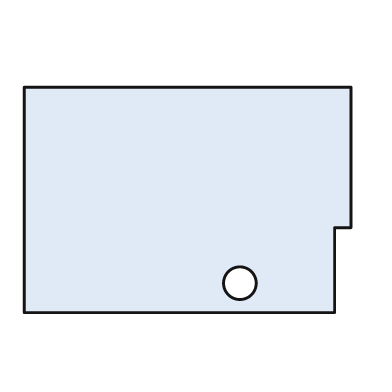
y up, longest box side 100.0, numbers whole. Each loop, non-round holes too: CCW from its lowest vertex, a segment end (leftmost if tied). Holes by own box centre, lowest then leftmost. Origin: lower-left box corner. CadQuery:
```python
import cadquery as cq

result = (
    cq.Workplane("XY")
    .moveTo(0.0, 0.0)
    .lineTo(95.0, 0.0)
    .lineTo(95.0, 26.0)
    .lineTo(100.0, 26.0)
    .lineTo(100.0, 69.0)
    .lineTo(0.0, 69.0)
    .close()
    .moveTo(66.0, 9.0)
    .circle(5.0)
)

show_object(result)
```